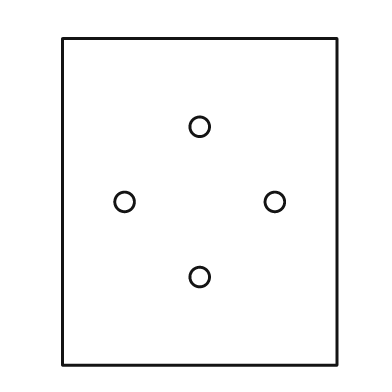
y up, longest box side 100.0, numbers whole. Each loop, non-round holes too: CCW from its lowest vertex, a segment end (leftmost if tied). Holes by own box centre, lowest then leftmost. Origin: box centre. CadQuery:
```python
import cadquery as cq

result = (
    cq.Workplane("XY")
    .moveTo(-42.0, -50.0)
    .lineTo(42.0, -50.0)
    .lineTo(42.0, 50.0)
    .lineTo(-42.0, 50.0)
    .close()
    .moveTo(0.0, -23.0)
    .circle(3.0)
    .moveTo(-23.0, 0.0)
    .circle(3.0)
    .moveTo(23.0, 0.0)
    .circle(3.0)
    .moveTo(0.0, 23.0)
    .circle(3.0)
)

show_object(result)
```